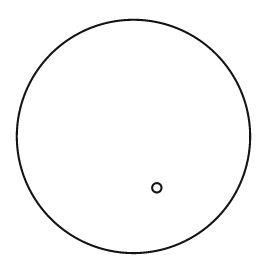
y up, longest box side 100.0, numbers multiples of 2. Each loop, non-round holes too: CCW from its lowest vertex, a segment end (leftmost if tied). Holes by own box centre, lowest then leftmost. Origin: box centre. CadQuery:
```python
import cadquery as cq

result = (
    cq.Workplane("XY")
    .moveTo(0.0, 0.0)
    .circle(50.0)
    .moveTo(10.0, -22.0)
    .circle(2.0)
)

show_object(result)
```